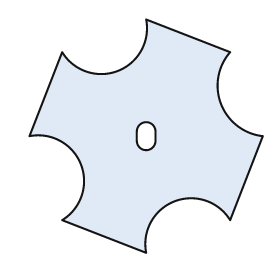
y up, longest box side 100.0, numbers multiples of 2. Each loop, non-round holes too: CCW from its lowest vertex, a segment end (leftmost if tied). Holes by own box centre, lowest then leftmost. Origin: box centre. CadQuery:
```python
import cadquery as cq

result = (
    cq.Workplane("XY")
    .moveTo(0.0, -50.0)
    .threePointArc((12.0, -28.0), (36.0, -36.0))
    .lineTo(50.0, 0.0)
    .threePointArc((32.0, 14.0), (36.0, 36.0))
    .lineTo(0.0, 50.0)
    .threePointArc((-12.0, 28.0), (-36.0, 36.0))
    .lineTo(-50.0, 0.0)
    .threePointArc((-28.0, -12.0), (-36.0, -36.0))
    .close()
    .moveTo(-4.0, -2.0)
    .threePointArc((0.0, -6.0), (4.0, -2.0))
    .lineTo(4.0, 2.0)
    .threePointArc((0.0, 6.0), (-4.0, 2.0))
    .close()
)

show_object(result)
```